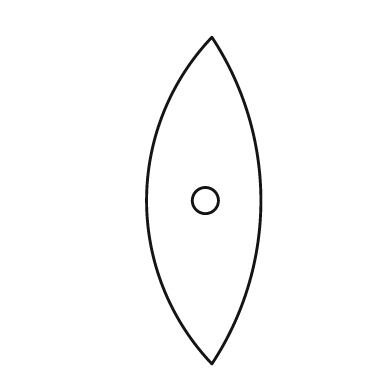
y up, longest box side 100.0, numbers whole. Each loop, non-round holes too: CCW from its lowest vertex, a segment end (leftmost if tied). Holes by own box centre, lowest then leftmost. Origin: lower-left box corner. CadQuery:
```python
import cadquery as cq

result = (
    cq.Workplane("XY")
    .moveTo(20.0, 0.0)
    .threePointArc((35.0, 50.0), (20.0, 100.0))
    .threePointArc((0.0, 50.0), (20.0, 0.0))
    .close()
    .moveTo(18.0, 50.0)
    .circle(4.0)
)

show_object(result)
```